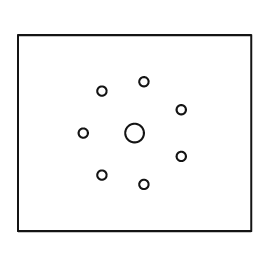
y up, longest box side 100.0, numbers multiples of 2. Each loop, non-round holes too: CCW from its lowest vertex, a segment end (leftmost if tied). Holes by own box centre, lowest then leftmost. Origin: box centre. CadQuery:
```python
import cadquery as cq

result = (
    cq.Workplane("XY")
    .moveTo(-50.0, -42.0)
    .lineTo(50.0, -42.0)
    .lineTo(50.0, 42.0)
    .lineTo(-50.0, 42.0)
    .close()
    .moveTo(4.0, -22.0)
    .circle(2.0)
    .moveTo(-14.0, -18.0)
    .circle(2.0)
    .moveTo(20.0, -10.0)
    .circle(2.0)
    .moveTo(-22.0, 0.0)
    .circle(2.0)
    .moveTo(0.0, 0.0)
    .circle(4.0)
    .moveTo(20.0, 10.0)
    .circle(2.0)
    .moveTo(-14.0, 18.0)
    .circle(2.0)
    .moveTo(4.0, 22.0)
    .circle(2.0)
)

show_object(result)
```